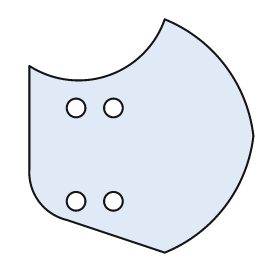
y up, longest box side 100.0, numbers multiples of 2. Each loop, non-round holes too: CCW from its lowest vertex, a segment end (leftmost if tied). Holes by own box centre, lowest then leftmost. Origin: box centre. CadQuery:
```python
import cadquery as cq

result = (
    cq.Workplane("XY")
    .moveTo(10.0, -50.0)
    .threePointArc((36.0, -30.0), (48.0, 0.0))
    .threePointArc((36.0, 30.0), (10.0, 50.0))
    .threePointArc((-14.0, 26.0), (-48.0, 30.0))
    .lineTo(-48.0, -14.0)
    .threePointArc((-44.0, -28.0), (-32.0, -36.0))
    .close()
    .moveTo(-28.0, -28.0)
    .circle(4.0)
    .moveTo(-12.0, -28.0)
    .circle(4.0)
    .moveTo(-28.0, 12.0)
    .circle(4.0)
    .moveTo(-12.0, 12.0)
    .circle(4.0)
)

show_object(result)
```